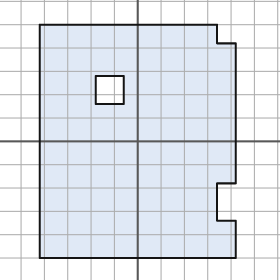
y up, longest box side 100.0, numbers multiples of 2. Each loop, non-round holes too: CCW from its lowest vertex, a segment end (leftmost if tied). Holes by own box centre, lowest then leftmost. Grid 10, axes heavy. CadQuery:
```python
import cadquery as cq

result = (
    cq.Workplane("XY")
    .moveTo(-42.0, -50.0)
    .lineTo(42.0, -50.0)
    .lineTo(42.0, -34.0)
    .lineTo(34.0, -34.0)
    .lineTo(34.0, -18.0)
    .lineTo(42.0, -18.0)
    .lineTo(42.0, 42.0)
    .lineTo(34.0, 42.0)
    .lineTo(34.0, 50.0)
    .lineTo(-42.0, 50.0)
    .close()
    .moveTo(-18.0, 16.0)
    .lineTo(-6.0, 16.0)
    .lineTo(-6.0, 28.0)
    .lineTo(-18.0, 28.0)
    .close()
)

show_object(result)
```